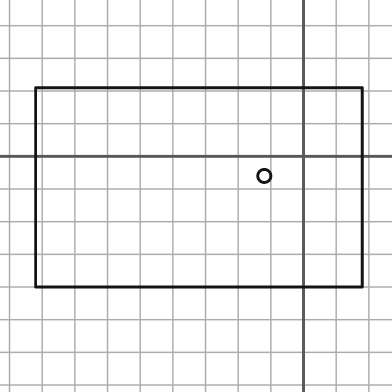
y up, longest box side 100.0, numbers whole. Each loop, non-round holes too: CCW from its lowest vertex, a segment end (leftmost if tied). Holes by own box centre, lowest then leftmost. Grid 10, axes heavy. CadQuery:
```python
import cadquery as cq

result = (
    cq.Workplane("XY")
    .moveTo(-82.0, -40.0)
    .lineTo(18.0, -40.0)
    .lineTo(18.0, 21.0)
    .lineTo(-82.0, 21.0)
    .close()
    .moveTo(-12.0, -6.0)
    .circle(2.0)
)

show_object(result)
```